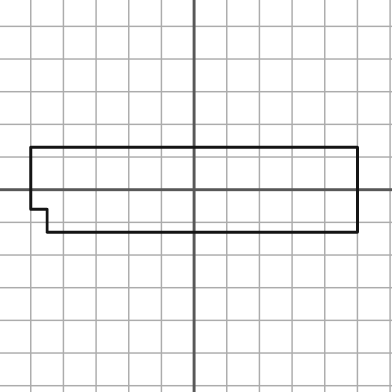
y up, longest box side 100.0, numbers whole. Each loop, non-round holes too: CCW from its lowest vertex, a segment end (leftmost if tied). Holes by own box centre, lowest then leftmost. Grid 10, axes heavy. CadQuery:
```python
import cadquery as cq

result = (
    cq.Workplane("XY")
    .moveTo(-45.0, -13.0)
    .lineTo(50.0, -13.0)
    .lineTo(50.0, 13.0)
    .lineTo(-50.0, 13.0)
    .lineTo(-50.0, -6.0)
    .lineTo(-45.0, -6.0)
    .close()
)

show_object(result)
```